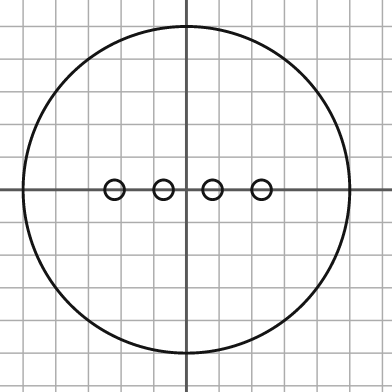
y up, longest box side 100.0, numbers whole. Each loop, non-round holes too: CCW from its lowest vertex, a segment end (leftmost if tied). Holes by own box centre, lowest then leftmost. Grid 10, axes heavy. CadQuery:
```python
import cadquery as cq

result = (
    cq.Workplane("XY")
    .moveTo(0.0, 0.0)
    .circle(50.0)
    .moveTo(-22.0, 0.0)
    .circle(3.0)
    .moveTo(-7.0, 0.0)
    .circle(3.0)
    .moveTo(8.0, 0.0)
    .circle(3.0)
    .moveTo(23.0, 0.0)
    .circle(3.0)
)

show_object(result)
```